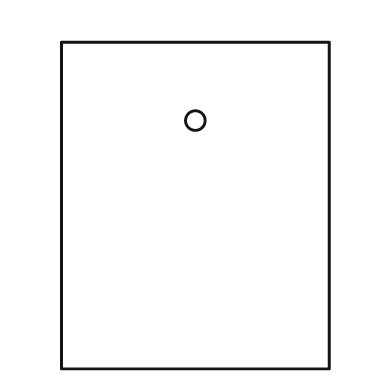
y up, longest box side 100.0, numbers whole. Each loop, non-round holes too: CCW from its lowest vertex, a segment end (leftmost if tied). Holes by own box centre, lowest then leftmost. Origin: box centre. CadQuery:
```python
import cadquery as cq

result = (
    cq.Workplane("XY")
    .moveTo(-41.0, -50.0)
    .lineTo(41.0, -50.0)
    .lineTo(41.0, 50.0)
    .lineTo(-41.0, 50.0)
    .close()
    .moveTo(0.0, 26.0)
    .circle(3.0)
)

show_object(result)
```